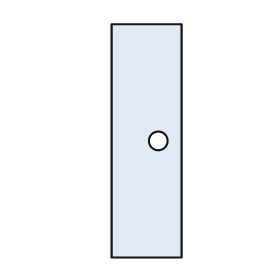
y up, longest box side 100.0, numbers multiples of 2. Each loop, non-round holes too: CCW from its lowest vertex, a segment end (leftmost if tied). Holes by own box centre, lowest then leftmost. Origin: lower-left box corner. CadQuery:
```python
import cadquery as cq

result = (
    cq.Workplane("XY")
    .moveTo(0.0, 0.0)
    .lineTo(30.0, 0.0)
    .lineTo(30.0, 100.0)
    .lineTo(0.0, 100.0)
    .close()
    .moveTo(20.0, 50.0)
    .circle(4.0)
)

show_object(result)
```